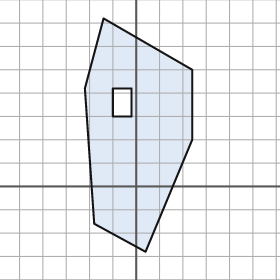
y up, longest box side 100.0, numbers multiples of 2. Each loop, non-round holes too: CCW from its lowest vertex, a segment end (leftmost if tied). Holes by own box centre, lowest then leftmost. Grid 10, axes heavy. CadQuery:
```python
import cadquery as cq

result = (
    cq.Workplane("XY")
    .moveTo(4.0, -28.0)
    .lineTo(24.0, 20.0)
    .lineTo(24.0, 50.0)
    .lineTo(-14.0, 72.0)
    .lineTo(-22.0, 42.0)
    .lineTo(-18.0, -16.0)
    .close()
    .moveTo(-10.0, 30.0)
    .lineTo(-2.0, 30.0)
    .lineTo(-2.0, 42.0)
    .lineTo(-10.0, 42.0)
    .close()
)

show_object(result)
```